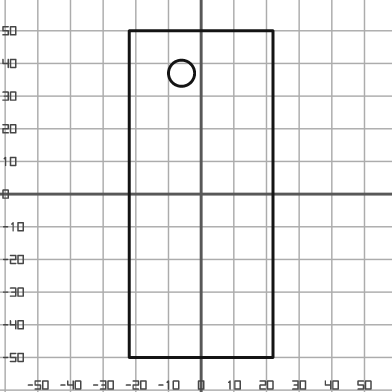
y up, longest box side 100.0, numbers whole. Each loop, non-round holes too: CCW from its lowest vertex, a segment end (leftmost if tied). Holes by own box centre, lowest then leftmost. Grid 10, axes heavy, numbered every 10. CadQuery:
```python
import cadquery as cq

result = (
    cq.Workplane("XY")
    .moveTo(-22.0, -50.0)
    .lineTo(22.0, -50.0)
    .lineTo(22.0, 50.0)
    .lineTo(-22.0, 50.0)
    .close()
    .moveTo(-6.0, 37.0)
    .circle(4.0)
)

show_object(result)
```